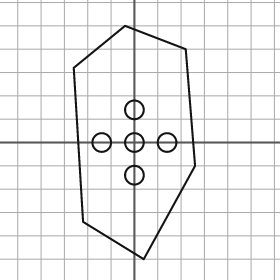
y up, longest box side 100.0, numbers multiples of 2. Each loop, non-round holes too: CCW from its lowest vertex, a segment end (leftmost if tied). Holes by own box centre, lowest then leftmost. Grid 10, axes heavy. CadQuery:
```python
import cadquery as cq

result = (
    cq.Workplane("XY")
    .moveTo(4.0, -50.0)
    .lineTo(26.0, -10.0)
    .lineTo(22.0, 40.0)
    .lineTo(-4.0, 50.0)
    .lineTo(-26.0, 32.0)
    .lineTo(-22.0, -34.0)
    .close()
    .moveTo(0.0, -14.0)
    .circle(4.0)
    .moveTo(-14.0, 0.0)
    .circle(4.0)
    .moveTo(0.0, 0.0)
    .circle(4.0)
    .moveTo(14.0, 0.0)
    .circle(4.0)
    .moveTo(0.0, 14.0)
    .circle(4.0)
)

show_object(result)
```